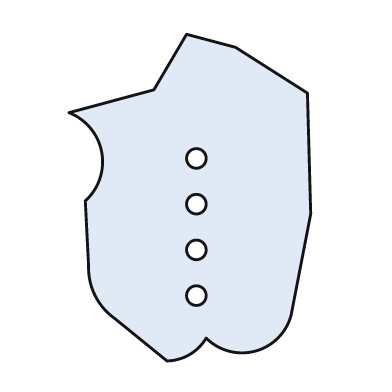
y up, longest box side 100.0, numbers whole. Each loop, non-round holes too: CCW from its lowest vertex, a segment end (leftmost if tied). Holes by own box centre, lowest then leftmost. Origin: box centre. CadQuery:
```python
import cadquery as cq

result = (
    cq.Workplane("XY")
    .moveTo(-7.0, -50.0)
    .threePointArc((0.0, -48.0), (5.0, -43.0))
    .threePointArc((20.0, -47.0), (31.0, -36.0))
    .lineTo(37.0, -5.0)
    .lineTo(36.0, 32.0)
    .lineTo(14.0, 46.0)
    .lineTo(-1.0, 50.0)
    .lineTo(-11.0, 33.0)
    .lineTo(-37.0, 26.0)
    .threePointArc((-27.0, 14.0), (-32.0, -1.0))
    .lineTo(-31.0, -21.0)
    .threePointArc((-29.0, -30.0), (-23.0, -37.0))
    .close()
    .moveTo(2.0, -30.0)
    .circle(3.0)
    .moveTo(2.0, -16.0)
    .circle(3.0)
    .moveTo(2.0, -2.0)
    .circle(3.0)
    .moveTo(2.0, 12.0)
    .circle(3.0)
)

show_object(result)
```